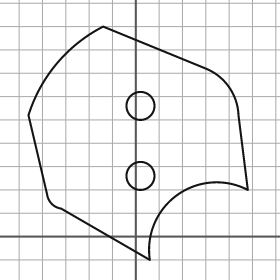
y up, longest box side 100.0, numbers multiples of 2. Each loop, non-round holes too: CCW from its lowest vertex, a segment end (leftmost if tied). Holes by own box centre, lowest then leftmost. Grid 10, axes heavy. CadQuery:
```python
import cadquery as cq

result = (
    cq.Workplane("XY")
    .moveTo(6.0, -10.0)
    .threePointArc((18.0, 18.0), (48.0, 20.0))
    .lineTo(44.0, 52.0)
    .threePointArc((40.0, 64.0), (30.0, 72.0))
    .lineTo(-14.0, 90.0)
    .threePointArc((-34.0, 74.0), (-46.0, 52.0))
    .lineTo(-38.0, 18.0)
    .threePointArc((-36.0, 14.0), (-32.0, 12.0))
    .close()
    .moveTo(2.0, 26.0)
    .circle(6.0)
    .moveTo(2.0, 56.0)
    .circle(6.0)
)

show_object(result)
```